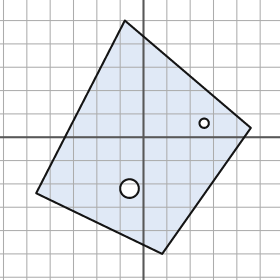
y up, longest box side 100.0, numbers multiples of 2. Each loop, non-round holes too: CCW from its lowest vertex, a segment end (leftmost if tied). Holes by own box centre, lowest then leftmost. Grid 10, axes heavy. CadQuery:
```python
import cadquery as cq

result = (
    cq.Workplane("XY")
    .moveTo(8.0, -50.0)
    .lineTo(46.0, 4.0)
    .lineTo(-8.0, 50.0)
    .lineTo(-46.0, -24.0)
    .close()
    .moveTo(-6.0, -22.0)
    .circle(4.0)
    .moveTo(26.0, 6.0)
    .circle(2.0)
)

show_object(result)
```